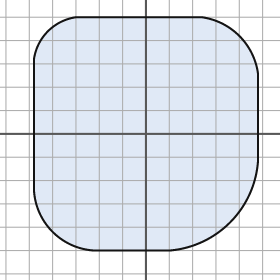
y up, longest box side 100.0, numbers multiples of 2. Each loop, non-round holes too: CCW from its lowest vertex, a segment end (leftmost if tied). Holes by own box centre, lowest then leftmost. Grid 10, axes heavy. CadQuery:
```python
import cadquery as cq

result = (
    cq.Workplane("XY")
    .moveTo(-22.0, -50.0)
    .lineTo(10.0, -50.0)
    .threePointArc((36.0, -38.0), (48.0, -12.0))
    .lineTo(48.0, 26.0)
    .threePointArc((40.0, 42.0), (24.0, 50.0))
    .lineTo(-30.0, 50.0)
    .threePointArc((-42.0, 44.0), (-48.0, 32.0))
    .lineTo(-48.0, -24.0)
    .threePointArc((-40.0, -42.0), (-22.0, -50.0))
    .close()
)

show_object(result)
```